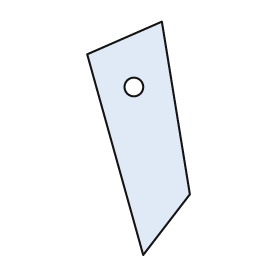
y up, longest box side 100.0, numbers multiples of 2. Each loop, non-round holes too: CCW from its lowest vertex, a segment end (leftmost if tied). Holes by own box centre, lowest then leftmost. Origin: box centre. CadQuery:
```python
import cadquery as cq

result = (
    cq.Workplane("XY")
    .moveTo(2.0, -50.0)
    .lineTo(22.0, -24.0)
    .lineTo(10.0, 50.0)
    .lineTo(-22.0, 36.0)
    .close()
    .moveTo(-2.0, 22.0)
    .circle(4.0)
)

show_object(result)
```